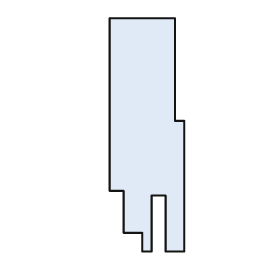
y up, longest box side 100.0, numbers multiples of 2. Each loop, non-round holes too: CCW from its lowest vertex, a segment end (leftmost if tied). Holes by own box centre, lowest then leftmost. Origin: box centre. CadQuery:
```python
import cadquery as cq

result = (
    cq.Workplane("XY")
    .moveTo(-2.0, -50.0)
    .lineTo(2.0, -50.0)
    .lineTo(2.0, -26.0)
    .lineTo(8.0, -26.0)
    .lineTo(8.0, -50.0)
    .lineTo(16.0, -50.0)
    .lineTo(16.0, 6.0)
    .lineTo(12.0, 6.0)
    .lineTo(12.0, 50.0)
    .lineTo(-16.0, 50.0)
    .lineTo(-16.0, -24.0)
    .lineTo(-10.0, -24.0)
    .lineTo(-10.0, -42.0)
    .lineTo(-2.0, -42.0)
    .close()
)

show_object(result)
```